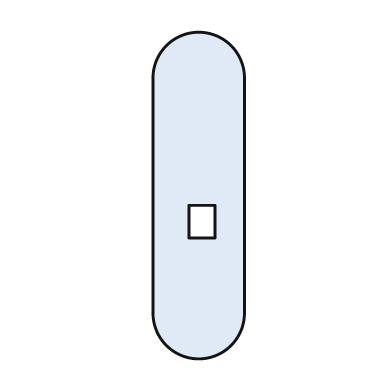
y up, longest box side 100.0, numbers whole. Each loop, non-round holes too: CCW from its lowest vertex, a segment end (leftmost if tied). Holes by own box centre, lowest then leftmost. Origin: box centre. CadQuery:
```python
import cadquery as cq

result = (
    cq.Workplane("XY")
    .moveTo(-14.0, -36.0)
    .threePointArc((0.0, -50.0), (14.0, -36.0))
    .lineTo(14.0, 36.0)
    .threePointArc((0.0, 50.0), (-14.0, 36.0))
    .close()
    .moveTo(-3.0, -13.0)
    .lineTo(5.0, -13.0)
    .lineTo(5.0, -3.0)
    .lineTo(-3.0, -3.0)
    .close()
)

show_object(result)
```